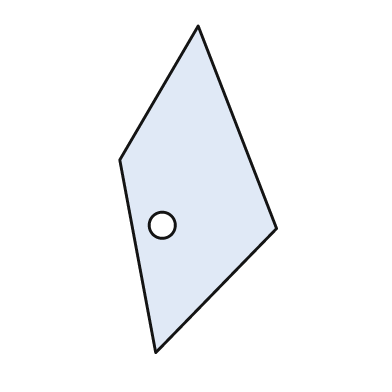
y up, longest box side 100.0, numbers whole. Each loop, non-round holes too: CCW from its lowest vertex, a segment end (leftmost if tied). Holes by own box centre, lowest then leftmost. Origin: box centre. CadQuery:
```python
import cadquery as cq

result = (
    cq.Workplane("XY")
    .moveTo(-13.0, -50.0)
    .lineTo(24.0, -12.0)
    .lineTo(0.0, 50.0)
    .lineTo(-24.0, 9.0)
    .close()
    .moveTo(-11.0, -11.0)
    .circle(4.0)
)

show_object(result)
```